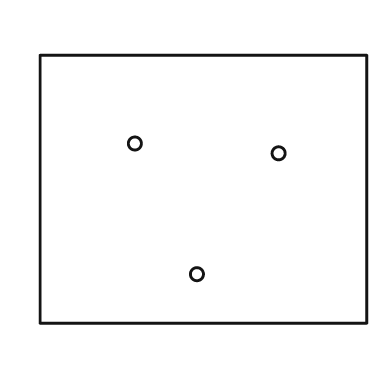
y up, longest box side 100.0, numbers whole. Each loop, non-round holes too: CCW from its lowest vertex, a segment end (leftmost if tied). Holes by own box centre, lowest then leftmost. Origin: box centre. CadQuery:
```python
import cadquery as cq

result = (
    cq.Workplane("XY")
    .moveTo(-50.0, -41.0)
    .lineTo(50.0, -41.0)
    .lineTo(50.0, 41.0)
    .lineTo(-50.0, 41.0)
    .close()
    .moveTo(-2.0, -26.0)
    .circle(2.0)
    .moveTo(23.0, 11.0)
    .circle(2.0)
    .moveTo(-21.0, 14.0)
    .circle(2.0)
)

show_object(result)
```